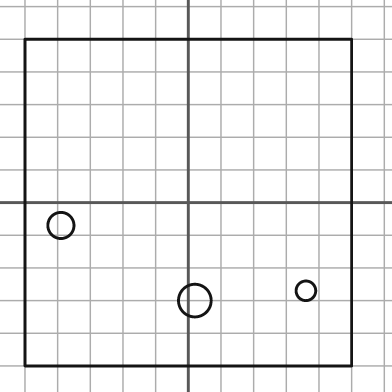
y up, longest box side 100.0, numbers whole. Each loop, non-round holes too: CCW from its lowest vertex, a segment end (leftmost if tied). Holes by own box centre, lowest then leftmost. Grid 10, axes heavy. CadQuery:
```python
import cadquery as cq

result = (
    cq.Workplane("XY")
    .moveTo(-50.0, -50.0)
    .lineTo(50.0, -50.0)
    .lineTo(50.0, 50.0)
    .lineTo(-50.0, 50.0)
    .close()
    .moveTo(2.0, -30.0)
    .circle(5.0)
    .moveTo(36.0, -27.0)
    .circle(3.0)
    .moveTo(-39.0, -7.0)
    .circle(4.0)
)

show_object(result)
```